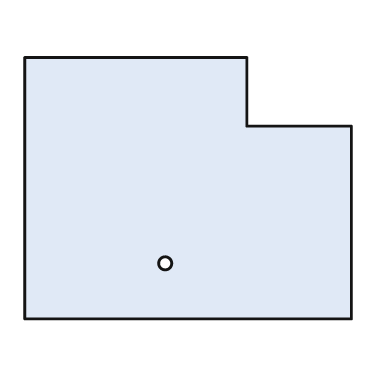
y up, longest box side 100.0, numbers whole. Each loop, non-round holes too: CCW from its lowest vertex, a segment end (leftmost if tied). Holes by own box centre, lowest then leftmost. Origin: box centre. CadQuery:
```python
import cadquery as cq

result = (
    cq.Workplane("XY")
    .moveTo(-50.0, -40.0)
    .lineTo(50.0, -40.0)
    .lineTo(50.0, 19.0)
    .lineTo(18.0, 19.0)
    .lineTo(18.0, 40.0)
    .lineTo(-50.0, 40.0)
    .close()
    .moveTo(-7.0, -23.0)
    .circle(2.0)
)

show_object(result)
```